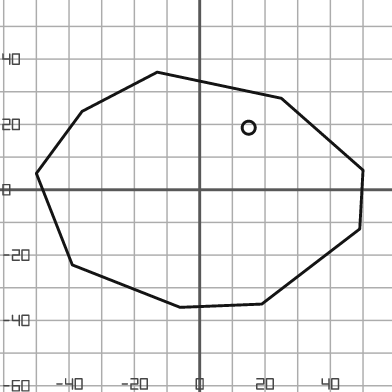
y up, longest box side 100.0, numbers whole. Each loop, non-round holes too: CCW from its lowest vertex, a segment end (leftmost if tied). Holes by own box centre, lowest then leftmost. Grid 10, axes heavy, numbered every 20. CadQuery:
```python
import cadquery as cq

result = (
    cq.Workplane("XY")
    .moveTo(-6.0, -36.0)
    .lineTo(19.0, -35.0)
    .lineTo(49.0, -12.0)
    .lineTo(50.0, 6.0)
    .lineTo(25.0, 28.0)
    .lineTo(-13.0, 36.0)
    .lineTo(-36.0, 24.0)
    .lineTo(-50.0, 5.0)
    .lineTo(-39.0, -23.0)
    .close()
    .moveTo(15.0, 19.0)
    .circle(2.0)
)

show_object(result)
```